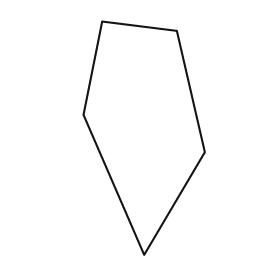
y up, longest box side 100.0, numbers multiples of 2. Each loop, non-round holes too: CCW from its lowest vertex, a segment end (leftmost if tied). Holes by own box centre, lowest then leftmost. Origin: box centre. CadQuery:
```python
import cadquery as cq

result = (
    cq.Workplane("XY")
    .moveTo(0.0, -50.0)
    .lineTo(26.0, -6.0)
    .lineTo(14.0, 46.0)
    .lineTo(-18.0, 50.0)
    .lineTo(-26.0, 10.0)
    .close()
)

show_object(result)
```